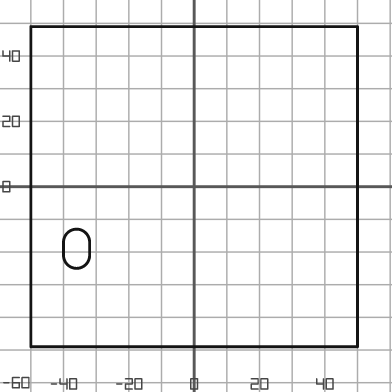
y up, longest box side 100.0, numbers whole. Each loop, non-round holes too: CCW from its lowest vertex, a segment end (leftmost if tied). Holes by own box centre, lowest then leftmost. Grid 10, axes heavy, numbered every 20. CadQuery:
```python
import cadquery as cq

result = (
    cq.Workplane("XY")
    .moveTo(-50.0, -49.0)
    .lineTo(50.0, -49.0)
    .lineTo(50.0, 49.0)
    .lineTo(-50.0, 49.0)
    .close()
    .moveTo(-40.0, -21.0)
    .threePointArc((-36.0, -25.0), (-32.0, -21.0))
    .lineTo(-32.0, -17.0)
    .threePointArc((-36.0, -13.0), (-40.0, -17.0))
    .close()
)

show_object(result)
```